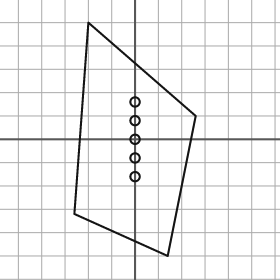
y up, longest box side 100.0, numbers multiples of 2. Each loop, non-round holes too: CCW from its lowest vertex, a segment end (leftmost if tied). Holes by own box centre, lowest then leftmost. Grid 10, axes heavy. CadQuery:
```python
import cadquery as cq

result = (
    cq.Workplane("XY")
    .moveTo(14.0, -50.0)
    .lineTo(26.0, 10.0)
    .lineTo(-20.0, 50.0)
    .lineTo(-26.0, -32.0)
    .close()
    .moveTo(0.0, -16.0)
    .circle(2.0)
    .moveTo(0.0, -8.0)
    .circle(2.0)
    .moveTo(0.0, 0.0)
    .circle(2.0)
    .moveTo(0.0, 8.0)
    .circle(2.0)
    .moveTo(0.0, 16.0)
    .circle(2.0)
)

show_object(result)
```